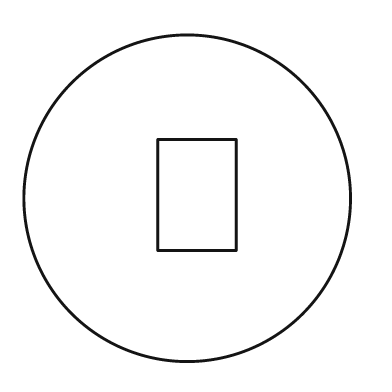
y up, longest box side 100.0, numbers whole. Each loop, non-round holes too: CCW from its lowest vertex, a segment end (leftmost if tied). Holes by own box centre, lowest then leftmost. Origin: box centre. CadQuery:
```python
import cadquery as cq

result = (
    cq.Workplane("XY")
    .moveTo(0.0, 0.0)
    .circle(50.0)
    .moveTo(-9.0, -16.0)
    .lineTo(15.0, -16.0)
    .lineTo(15.0, 18.0)
    .lineTo(-9.0, 18.0)
    .close()
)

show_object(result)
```